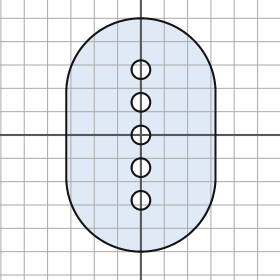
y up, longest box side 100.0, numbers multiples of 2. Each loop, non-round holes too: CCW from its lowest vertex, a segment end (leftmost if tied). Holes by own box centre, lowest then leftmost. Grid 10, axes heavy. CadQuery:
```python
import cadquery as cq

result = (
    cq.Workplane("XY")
    .moveTo(-32.0, -18.0)
    .threePointArc((0.0, -50.0), (32.0, -18.0))
    .lineTo(32.0, 18.0)
    .threePointArc((0.0, 50.0), (-32.0, 18.0))
    .close()
    .moveTo(0.0, -28.0)
    .circle(4.0)
    .moveTo(0.0, -14.0)
    .circle(4.0)
    .moveTo(0.0, 0.0)
    .circle(4.0)
    .moveTo(0.0, 14.0)
    .circle(4.0)
    .moveTo(0.0, 28.0)
    .circle(4.0)
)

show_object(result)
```